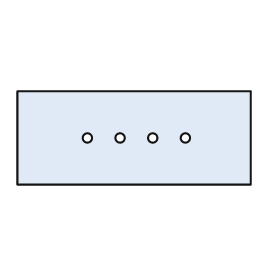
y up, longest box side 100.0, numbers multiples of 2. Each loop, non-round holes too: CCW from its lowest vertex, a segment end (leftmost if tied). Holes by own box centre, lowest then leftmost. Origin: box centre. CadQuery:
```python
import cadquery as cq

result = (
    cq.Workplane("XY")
    .moveTo(-50.0, -20.0)
    .lineTo(50.0, -20.0)
    .lineTo(50.0, 20.0)
    .lineTo(-50.0, 20.0)
    .close()
    .moveTo(-20.0, 0.0)
    .circle(2.0)
    .moveTo(-6.0, 0.0)
    .circle(2.0)
    .moveTo(8.0, 0.0)
    .circle(2.0)
    .moveTo(22.0, 0.0)
    .circle(2.0)
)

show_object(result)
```